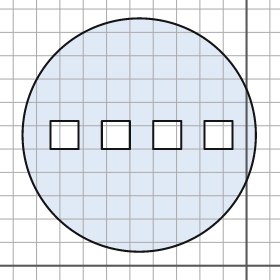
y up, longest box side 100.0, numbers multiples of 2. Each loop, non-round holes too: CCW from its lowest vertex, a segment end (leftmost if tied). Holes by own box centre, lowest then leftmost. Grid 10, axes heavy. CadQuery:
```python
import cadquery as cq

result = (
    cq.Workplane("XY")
    .moveTo(-46.0, 56.0)
    .circle(50.0)
    .moveTo(-84.0, 50.0)
    .lineTo(-72.0, 50.0)
    .lineTo(-72.0, 62.0)
    .lineTo(-84.0, 62.0)
    .close()
    .moveTo(-62.0, 50.0)
    .lineTo(-50.0, 50.0)
    .lineTo(-50.0, 62.0)
    .lineTo(-62.0, 62.0)
    .close()
    .moveTo(-40.0, 50.0)
    .lineTo(-28.0, 50.0)
    .lineTo(-28.0, 62.0)
    .lineTo(-40.0, 62.0)
    .close()
    .moveTo(-18.0, 50.0)
    .lineTo(-6.0, 50.0)
    .lineTo(-6.0, 62.0)
    .lineTo(-18.0, 62.0)
    .close()
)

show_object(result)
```